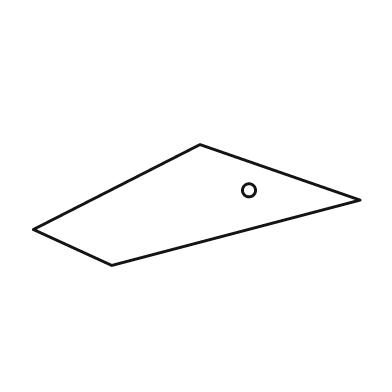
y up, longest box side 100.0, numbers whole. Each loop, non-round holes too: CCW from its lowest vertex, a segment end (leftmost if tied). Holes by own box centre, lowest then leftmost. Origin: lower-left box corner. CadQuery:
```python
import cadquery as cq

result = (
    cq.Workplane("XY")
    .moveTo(24.0, 0.0)
    .lineTo(100.0, 20.0)
    .lineTo(51.0, 37.0)
    .lineTo(0.0, 11.0)
    .close()
    .moveTo(66.0, 23.0)
    .circle(2.0)
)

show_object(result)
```